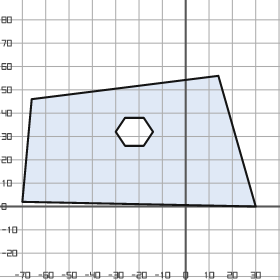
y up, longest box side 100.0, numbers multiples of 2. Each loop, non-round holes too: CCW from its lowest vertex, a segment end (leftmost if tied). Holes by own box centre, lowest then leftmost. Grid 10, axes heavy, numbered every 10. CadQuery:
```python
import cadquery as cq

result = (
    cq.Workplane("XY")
    .moveTo(30.0, 0.0)
    .lineTo(14.0, 56.0)
    .lineTo(-66.0, 46.0)
    .lineTo(-70.0, 2.0)
    .close()
    .moveTo(-26.0, 26.0)
    .lineTo(-18.0, 26.0)
    .lineTo(-14.0, 32.0)
    .lineTo(-18.0, 38.0)
    .lineTo(-26.0, 38.0)
    .lineTo(-30.0, 32.0)
    .close()
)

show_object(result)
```